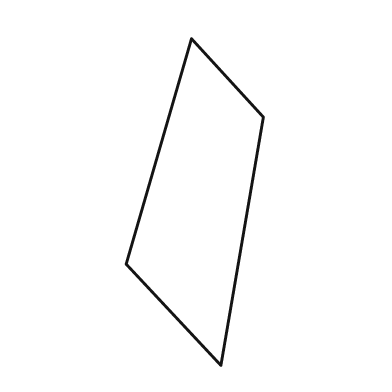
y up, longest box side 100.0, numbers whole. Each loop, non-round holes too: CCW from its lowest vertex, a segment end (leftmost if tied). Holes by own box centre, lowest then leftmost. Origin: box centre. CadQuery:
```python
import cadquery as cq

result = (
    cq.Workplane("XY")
    .moveTo(8.0, -50.0)
    .lineTo(21.0, 26.0)
    .lineTo(-1.0, 50.0)
    .lineTo(-21.0, -19.0)
    .close()
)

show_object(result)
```